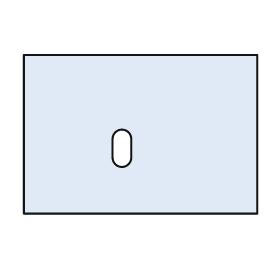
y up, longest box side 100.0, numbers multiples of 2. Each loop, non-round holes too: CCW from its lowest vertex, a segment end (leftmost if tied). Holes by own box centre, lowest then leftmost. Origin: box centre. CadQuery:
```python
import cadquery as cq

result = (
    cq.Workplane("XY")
    .moveTo(-50.0, -34.0)
    .lineTo(50.0, -34.0)
    .lineTo(50.0, 34.0)
    .lineTo(-50.0, 34.0)
    .close()
    .moveTo(-12.0, -10.0)
    .threePointArc((-8.0, -14.0), (-4.0, -10.0))
    .lineTo(-4.0, -2.0)
    .threePointArc((-8.0, 2.0), (-12.0, -2.0))
    .close()
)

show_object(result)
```